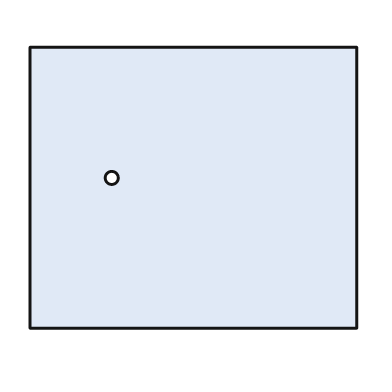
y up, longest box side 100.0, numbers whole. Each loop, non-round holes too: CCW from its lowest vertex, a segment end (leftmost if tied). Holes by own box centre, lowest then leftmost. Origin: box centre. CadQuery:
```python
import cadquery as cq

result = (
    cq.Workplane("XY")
    .moveTo(-50.0, -43.0)
    .lineTo(50.0, -43.0)
    .lineTo(50.0, 43.0)
    .lineTo(-50.0, 43.0)
    .close()
    .moveTo(-25.0, 3.0)
    .circle(2.0)
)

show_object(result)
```